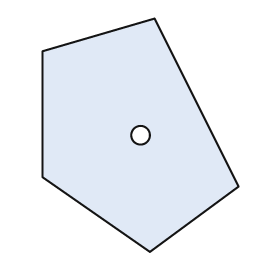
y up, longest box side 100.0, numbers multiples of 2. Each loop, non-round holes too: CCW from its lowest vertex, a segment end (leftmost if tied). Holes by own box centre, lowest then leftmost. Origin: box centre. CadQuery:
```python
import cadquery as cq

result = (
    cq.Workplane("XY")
    .moveTo(4.0, -50.0)
    .lineTo(42.0, -22.0)
    .lineTo(6.0, 50.0)
    .lineTo(-42.0, 36.0)
    .lineTo(-42.0, -18.0)
    .close()
    .moveTo(0.0, 0.0)
    .circle(4.0)
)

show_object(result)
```